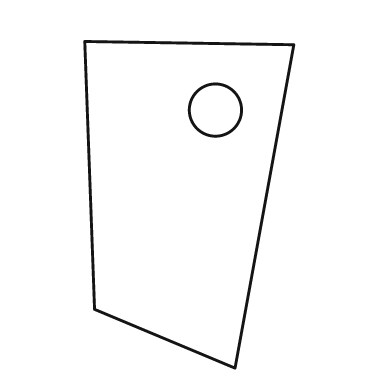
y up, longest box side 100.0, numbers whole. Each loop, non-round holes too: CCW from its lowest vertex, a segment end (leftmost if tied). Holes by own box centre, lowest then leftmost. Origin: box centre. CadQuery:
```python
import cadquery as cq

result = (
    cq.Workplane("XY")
    .moveTo(14.0, -50.0)
    .lineTo(32.0, 49.0)
    .lineTo(-32.0, 50.0)
    .lineTo(-29.0, -32.0)
    .close()
    .moveTo(8.0, 29.0)
    .circle(8.0)
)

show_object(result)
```